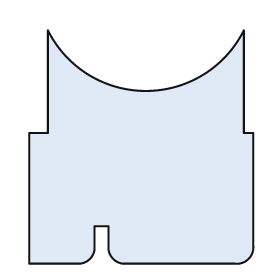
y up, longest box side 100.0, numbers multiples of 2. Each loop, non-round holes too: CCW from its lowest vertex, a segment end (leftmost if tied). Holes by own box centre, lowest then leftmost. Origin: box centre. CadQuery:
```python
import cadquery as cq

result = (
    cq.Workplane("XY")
    .moveTo(-48.0, -50.0)
    .lineTo(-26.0, -50.0)
    .threePointArc((-22.0, -48.0), (-20.0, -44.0))
    .lineTo(-20.0, -34.0)
    .lineTo(-14.0, -34.0)
    .lineTo(-14.0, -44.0)
    .threePointArc((-12.0, -48.0), (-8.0, -50.0))
    .lineTo(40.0, -50.0)
    .threePointArc((46.0, -48.0), (48.0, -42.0))
    .lineTo(48.0, 6.0)
    .lineTo(44.0, 6.0)
    .lineTo(44.0, 50.0)
    .threePointArc((2.0, 24.0), (-40.0, 50.0))
    .lineTo(-40.0, 6.0)
    .lineTo(-48.0, 6.0)
    .close()
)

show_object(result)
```